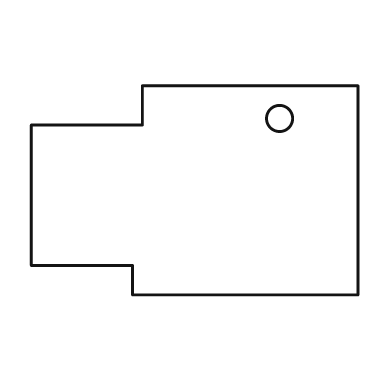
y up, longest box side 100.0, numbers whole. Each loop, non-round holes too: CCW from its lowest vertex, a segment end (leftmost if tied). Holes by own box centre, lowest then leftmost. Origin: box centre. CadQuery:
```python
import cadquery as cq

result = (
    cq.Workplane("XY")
    .moveTo(-19.0, -32.0)
    .lineTo(50.0, -32.0)
    .lineTo(50.0, 32.0)
    .lineTo(-16.0, 32.0)
    .lineTo(-16.0, 20.0)
    .lineTo(-50.0, 20.0)
    .lineTo(-50.0, -23.0)
    .lineTo(-19.0, -23.0)
    .close()
    .moveTo(26.0, 22.0)
    .circle(4.0)
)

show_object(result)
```